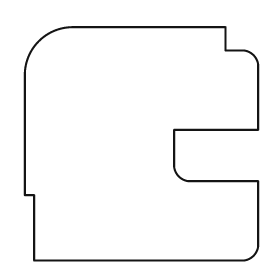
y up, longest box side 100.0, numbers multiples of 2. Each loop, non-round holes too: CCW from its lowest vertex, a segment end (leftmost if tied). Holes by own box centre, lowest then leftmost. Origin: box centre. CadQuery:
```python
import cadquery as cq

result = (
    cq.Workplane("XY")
    .moveTo(-46.0, -50.0)
    .lineTo(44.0, -50.0)
    .threePointArc((48.0, -48.0), (50.0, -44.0))
    .lineTo(50.0, -16.0)
    .lineTo(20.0, -16.0)
    .threePointArc((16.0, -14.0), (14.0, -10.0))
    .lineTo(14.0, 6.0)
    .lineTo(50.0, 6.0)
    .lineTo(50.0, 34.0)
    .threePointArc((48.0, 38.0), (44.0, 40.0))
    .lineTo(36.0, 40.0)
    .lineTo(36.0, 50.0)
    .lineTo(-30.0, 50.0)
    .threePointArc((-44.0, 44.0), (-50.0, 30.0))
    .lineTo(-50.0, -22.0)
    .lineTo(-46.0, -22.0)
    .close()
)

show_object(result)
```